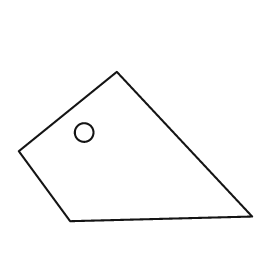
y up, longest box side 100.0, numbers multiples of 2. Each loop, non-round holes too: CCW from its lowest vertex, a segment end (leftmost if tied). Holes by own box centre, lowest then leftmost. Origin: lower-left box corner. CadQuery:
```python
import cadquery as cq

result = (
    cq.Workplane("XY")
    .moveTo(22.0, 0.0)
    .lineTo(100.0, 2.0)
    .lineTo(42.0, 64.0)
    .lineTo(0.0, 30.0)
    .close()
    .moveTo(28.0, 38.0)
    .circle(4.0)
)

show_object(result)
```